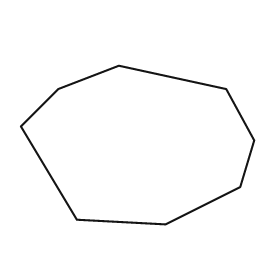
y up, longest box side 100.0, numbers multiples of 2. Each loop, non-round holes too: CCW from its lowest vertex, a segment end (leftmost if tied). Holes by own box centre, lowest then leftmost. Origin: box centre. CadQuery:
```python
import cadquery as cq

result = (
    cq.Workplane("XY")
    .moveTo(12.0, -34.0)
    .lineTo(44.0, -18.0)
    .lineTo(50.0, 2.0)
    .lineTo(38.0, 24.0)
    .lineTo(-8.0, 34.0)
    .lineTo(-34.0, 24.0)
    .lineTo(-50.0, 8.0)
    .lineTo(-26.0, -32.0)
    .close()
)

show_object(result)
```